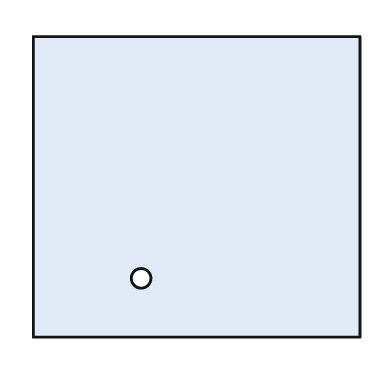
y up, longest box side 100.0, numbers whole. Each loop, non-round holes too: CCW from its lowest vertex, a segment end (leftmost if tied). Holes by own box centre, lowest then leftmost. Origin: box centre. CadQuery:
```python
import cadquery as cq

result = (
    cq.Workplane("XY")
    .moveTo(-50.0, -46.0)
    .lineTo(50.0, -46.0)
    .lineTo(50.0, 46.0)
    .lineTo(-50.0, 46.0)
    .close()
    .moveTo(-17.0, -28.0)
    .circle(3.0)
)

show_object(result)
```